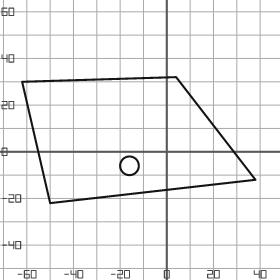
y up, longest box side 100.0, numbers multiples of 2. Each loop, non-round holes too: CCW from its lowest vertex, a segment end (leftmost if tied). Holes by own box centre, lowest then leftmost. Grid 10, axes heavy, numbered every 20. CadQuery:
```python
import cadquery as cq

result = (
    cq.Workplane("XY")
    .moveTo(-50.0, -22.0)
    .lineTo(38.0, -12.0)
    .lineTo(4.0, 32.0)
    .lineTo(-62.0, 30.0)
    .close()
    .moveTo(-16.0, -6.0)
    .circle(4.0)
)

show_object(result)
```